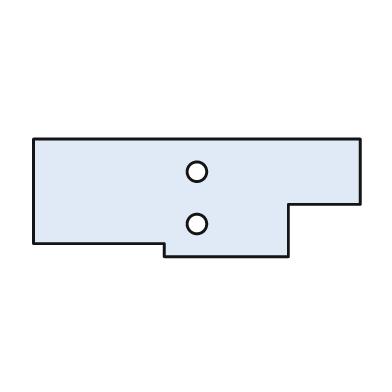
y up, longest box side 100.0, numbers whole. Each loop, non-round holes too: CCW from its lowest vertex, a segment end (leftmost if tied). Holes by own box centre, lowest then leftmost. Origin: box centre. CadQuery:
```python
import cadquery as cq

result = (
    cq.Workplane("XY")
    .moveTo(-10.0, -18.0)
    .lineTo(28.0, -18.0)
    .lineTo(28.0, -2.0)
    .lineTo(50.0, -2.0)
    .lineTo(50.0, 18.0)
    .lineTo(-50.0, 18.0)
    .lineTo(-50.0, -14.0)
    .lineTo(-10.0, -14.0)
    .close()
    .moveTo(0.0, -8.0)
    .circle(3.0)
    .moveTo(0.0, 8.0)
    .circle(3.0)
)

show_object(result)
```